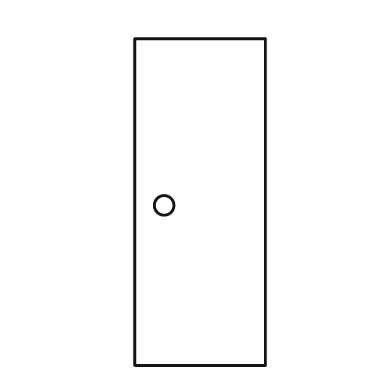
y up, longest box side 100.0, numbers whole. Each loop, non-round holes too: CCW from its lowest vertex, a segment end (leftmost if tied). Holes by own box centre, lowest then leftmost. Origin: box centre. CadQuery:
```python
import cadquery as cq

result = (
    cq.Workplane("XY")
    .moveTo(-20.0, -50.0)
    .lineTo(20.0, -50.0)
    .lineTo(20.0, 50.0)
    .lineTo(-20.0, 50.0)
    .close()
    .moveTo(-11.0, -1.0)
    .circle(3.0)
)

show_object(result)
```